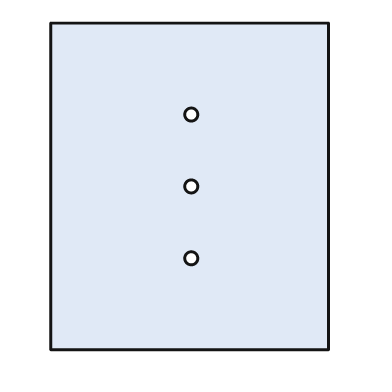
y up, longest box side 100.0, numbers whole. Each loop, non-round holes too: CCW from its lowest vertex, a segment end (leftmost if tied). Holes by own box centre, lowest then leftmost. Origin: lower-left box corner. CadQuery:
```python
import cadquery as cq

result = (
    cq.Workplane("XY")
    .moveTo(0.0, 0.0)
    .lineTo(85.0, 0.0)
    .lineTo(85.0, 100.0)
    .lineTo(0.0, 100.0)
    .close()
    .moveTo(43.0, 28.0)
    .circle(2.0)
    .moveTo(43.0, 50.0)
    .circle(2.0)
    .moveTo(43.0, 72.0)
    .circle(2.0)
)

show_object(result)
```